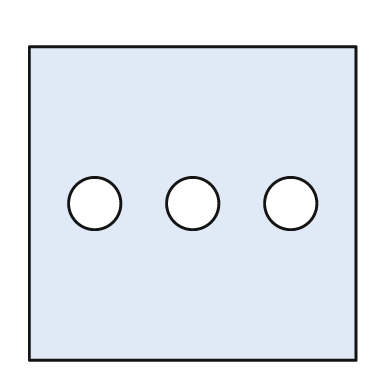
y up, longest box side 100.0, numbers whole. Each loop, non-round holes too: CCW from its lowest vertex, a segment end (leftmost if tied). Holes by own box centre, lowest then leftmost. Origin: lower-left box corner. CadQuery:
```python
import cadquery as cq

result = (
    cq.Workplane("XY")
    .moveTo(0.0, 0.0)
    .lineTo(100.0, 0.0)
    .lineTo(100.0, 96.0)
    .lineTo(0.0, 96.0)
    .close()
    .moveTo(20.0, 48.0)
    .circle(8.0)
    .moveTo(50.0, 48.0)
    .circle(8.0)
    .moveTo(80.0, 48.0)
    .circle(8.0)
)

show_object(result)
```